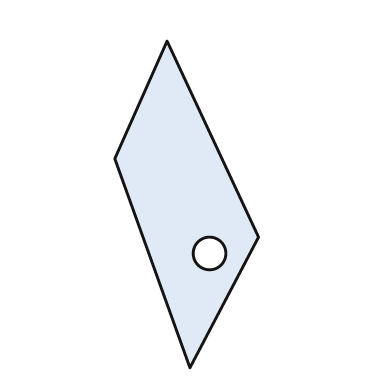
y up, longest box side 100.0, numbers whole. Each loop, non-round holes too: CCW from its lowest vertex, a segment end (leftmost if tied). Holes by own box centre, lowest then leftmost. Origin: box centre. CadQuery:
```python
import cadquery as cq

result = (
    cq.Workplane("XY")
    .moveTo(1.0, -50.0)
    .lineTo(22.0, -10.0)
    .lineTo(-6.0, 50.0)
    .lineTo(-22.0, 14.0)
    .close()
    .moveTo(7.0, -15.0)
    .circle(5.0)
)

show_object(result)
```